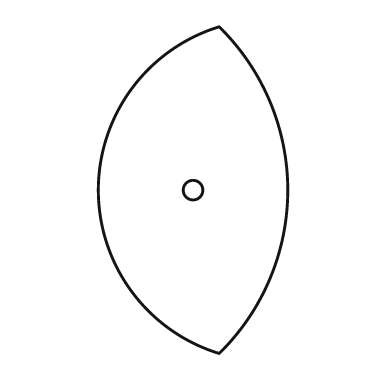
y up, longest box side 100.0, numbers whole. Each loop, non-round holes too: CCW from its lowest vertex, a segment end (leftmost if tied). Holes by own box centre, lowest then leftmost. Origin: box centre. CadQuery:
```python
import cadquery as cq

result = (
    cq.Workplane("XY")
    .moveTo(8.0, -50.0)
    .threePointArc((29.0, 0.0), (8.0, 50.0))
    .threePointArc((-29.0, 0.0), (8.0, -50.0))
    .close()
    .moveTo(0.0, 0.0)
    .circle(3.0)
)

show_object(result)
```